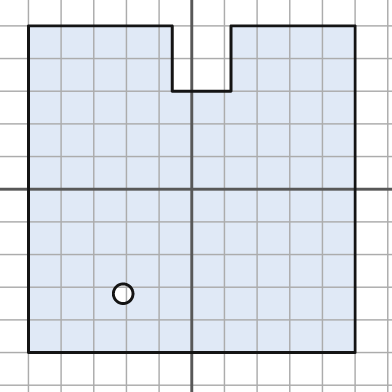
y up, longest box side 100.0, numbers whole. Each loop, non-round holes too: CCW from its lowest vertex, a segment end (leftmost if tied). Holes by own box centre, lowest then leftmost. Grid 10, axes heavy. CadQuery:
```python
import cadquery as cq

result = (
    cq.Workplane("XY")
    .moveTo(-50.0, -50.0)
    .lineTo(50.0, -50.0)
    .lineTo(50.0, 50.0)
    .lineTo(12.0, 50.0)
    .lineTo(12.0, 30.0)
    .lineTo(-6.0, 30.0)
    .lineTo(-6.0, 50.0)
    .lineTo(-50.0, 50.0)
    .close()
    .moveTo(-21.0, -32.0)
    .circle(3.0)
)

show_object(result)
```